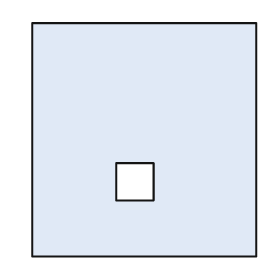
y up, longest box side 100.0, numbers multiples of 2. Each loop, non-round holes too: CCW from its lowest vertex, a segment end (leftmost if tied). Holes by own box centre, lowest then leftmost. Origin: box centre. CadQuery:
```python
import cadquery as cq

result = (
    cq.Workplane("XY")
    .moveTo(-48.0, -50.0)
    .lineTo(48.0, -50.0)
    .lineTo(48.0, 50.0)
    .lineTo(-48.0, 50.0)
    .close()
    .moveTo(-12.0, -26.0)
    .lineTo(4.0, -26.0)
    .lineTo(4.0, -10.0)
    .lineTo(-12.0, -10.0)
    .close()
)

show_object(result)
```